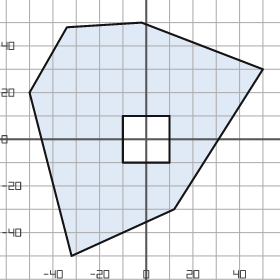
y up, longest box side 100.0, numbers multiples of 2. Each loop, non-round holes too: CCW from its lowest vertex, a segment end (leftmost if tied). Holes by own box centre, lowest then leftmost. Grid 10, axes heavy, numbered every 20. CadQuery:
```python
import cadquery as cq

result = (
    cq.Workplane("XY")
    .moveTo(-32.0, -50.0)
    .lineTo(12.0, -30.0)
    .lineTo(50.0, 30.0)
    .lineTo(-2.0, 50.0)
    .lineTo(-34.0, 48.0)
    .lineTo(-50.0, 20.0)
    .close()
    .moveTo(-10.0, -10.0)
    .lineTo(10.0, -10.0)
    .lineTo(10.0, 10.0)
    .lineTo(-10.0, 10.0)
    .close()
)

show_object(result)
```